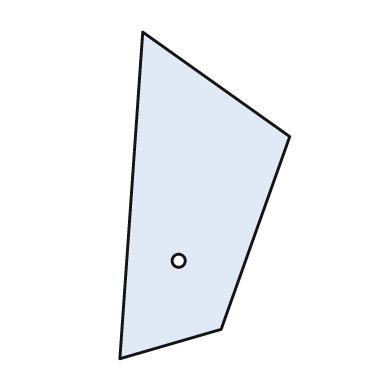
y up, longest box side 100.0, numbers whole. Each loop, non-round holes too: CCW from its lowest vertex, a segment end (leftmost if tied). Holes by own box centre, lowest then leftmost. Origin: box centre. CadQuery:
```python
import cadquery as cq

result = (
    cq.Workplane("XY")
    .moveTo(-26.0, -50.0)
    .lineTo(5.0, -41.0)
    .lineTo(26.0, 18.0)
    .lineTo(-19.0, 50.0)
    .close()
    .moveTo(-8.0, -20.0)
    .circle(2.0)
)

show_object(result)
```